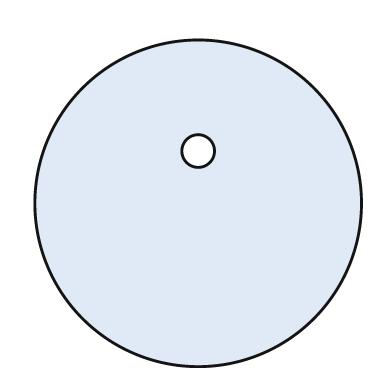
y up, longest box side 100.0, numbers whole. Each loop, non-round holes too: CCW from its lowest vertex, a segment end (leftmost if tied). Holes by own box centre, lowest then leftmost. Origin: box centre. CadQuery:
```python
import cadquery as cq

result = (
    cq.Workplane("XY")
    .moveTo(0.0, 0.0)
    .circle(50.0)
    .moveTo(0.0, 16.0)
    .circle(5.0)
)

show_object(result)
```